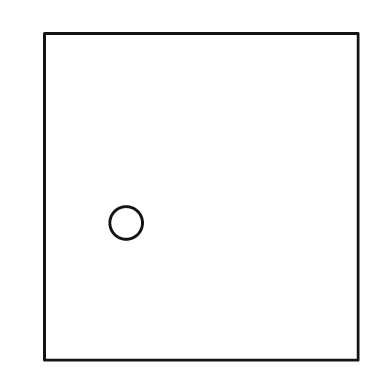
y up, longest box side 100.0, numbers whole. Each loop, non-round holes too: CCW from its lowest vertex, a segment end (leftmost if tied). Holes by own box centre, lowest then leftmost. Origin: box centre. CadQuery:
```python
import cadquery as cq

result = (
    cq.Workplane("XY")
    .moveTo(-48.0, -50.0)
    .lineTo(48.0, -50.0)
    .lineTo(48.0, 50.0)
    .lineTo(-48.0, 50.0)
    .close()
    .moveTo(-23.0, -8.0)
    .circle(5.0)
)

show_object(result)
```